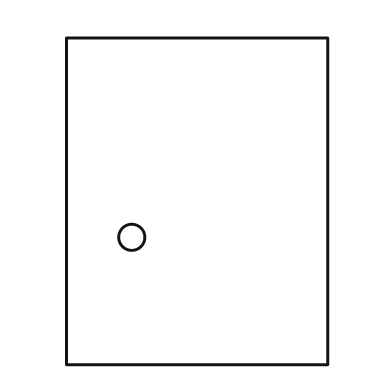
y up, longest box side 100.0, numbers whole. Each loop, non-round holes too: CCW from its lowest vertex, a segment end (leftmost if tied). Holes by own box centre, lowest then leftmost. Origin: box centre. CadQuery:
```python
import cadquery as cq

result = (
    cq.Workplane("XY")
    .moveTo(-40.0, -50.0)
    .lineTo(40.0, -50.0)
    .lineTo(40.0, 50.0)
    .lineTo(-40.0, 50.0)
    .close()
    .moveTo(-20.0, -11.0)
    .circle(4.0)
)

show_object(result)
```